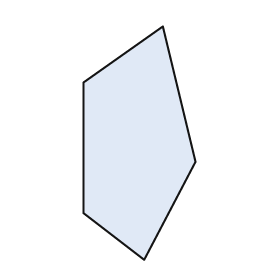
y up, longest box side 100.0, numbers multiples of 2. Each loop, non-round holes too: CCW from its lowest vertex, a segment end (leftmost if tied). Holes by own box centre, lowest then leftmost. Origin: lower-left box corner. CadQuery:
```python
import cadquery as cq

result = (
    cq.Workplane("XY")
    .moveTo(26.0, 0.0)
    .lineTo(48.0, 42.0)
    .lineTo(34.0, 100.0)
    .lineTo(0.0, 76.0)
    .lineTo(0.0, 20.0)
    .close()
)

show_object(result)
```